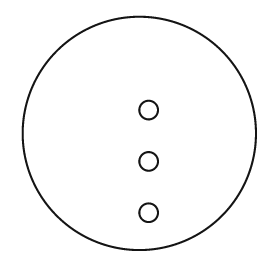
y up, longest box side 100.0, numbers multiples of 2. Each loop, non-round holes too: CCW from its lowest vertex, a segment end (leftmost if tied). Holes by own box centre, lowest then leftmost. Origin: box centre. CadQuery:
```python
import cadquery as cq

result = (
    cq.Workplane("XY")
    .moveTo(0.0, 0.0)
    .circle(50.0)
    .moveTo(4.0, -34.0)
    .circle(4.0)
    .moveTo(4.0, -12.0)
    .circle(4.0)
    .moveTo(4.0, 10.0)
    .circle(4.0)
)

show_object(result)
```